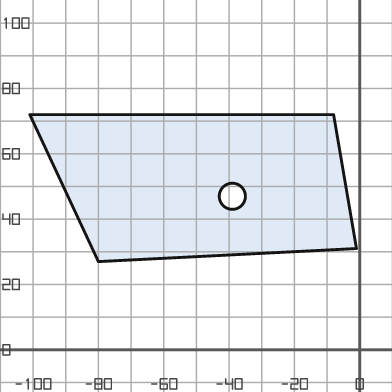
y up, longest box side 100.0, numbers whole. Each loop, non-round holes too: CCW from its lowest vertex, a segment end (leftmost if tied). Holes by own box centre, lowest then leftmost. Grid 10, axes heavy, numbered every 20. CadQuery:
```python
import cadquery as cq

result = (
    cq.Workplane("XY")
    .moveTo(-80.0, 27.0)
    .lineTo(-1.0, 31.0)
    .lineTo(-8.0, 72.0)
    .lineTo(-101.0, 72.0)
    .close()
    .moveTo(-39.0, 47.0)
    .circle(4.0)
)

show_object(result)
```